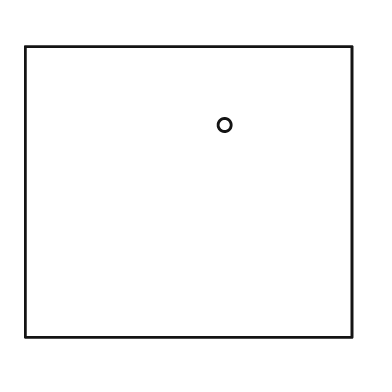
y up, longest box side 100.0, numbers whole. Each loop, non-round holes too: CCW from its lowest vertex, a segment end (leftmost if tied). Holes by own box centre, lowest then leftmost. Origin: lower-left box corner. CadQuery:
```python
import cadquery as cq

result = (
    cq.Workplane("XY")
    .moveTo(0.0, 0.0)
    .lineTo(100.0, 0.0)
    .lineTo(100.0, 89.0)
    .lineTo(0.0, 89.0)
    .close()
    .moveTo(61.0, 65.0)
    .circle(2.0)
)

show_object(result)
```